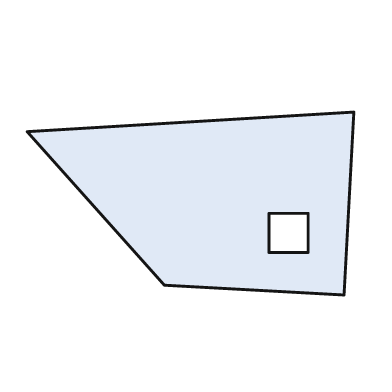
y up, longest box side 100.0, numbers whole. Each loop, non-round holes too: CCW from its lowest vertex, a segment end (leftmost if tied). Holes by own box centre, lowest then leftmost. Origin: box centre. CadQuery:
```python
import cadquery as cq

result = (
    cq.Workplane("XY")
    .moveTo(47.0, -28.0)
    .lineTo(50.0, 28.0)
    .lineTo(-50.0, 22.0)
    .lineTo(-8.0, -25.0)
    .close()
    .moveTo(24.0, -15.0)
    .lineTo(36.0, -15.0)
    .lineTo(36.0, -3.0)
    .lineTo(24.0, -3.0)
    .close()
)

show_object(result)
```